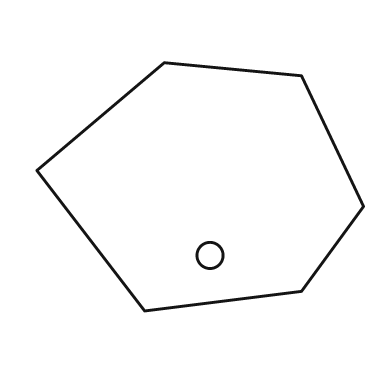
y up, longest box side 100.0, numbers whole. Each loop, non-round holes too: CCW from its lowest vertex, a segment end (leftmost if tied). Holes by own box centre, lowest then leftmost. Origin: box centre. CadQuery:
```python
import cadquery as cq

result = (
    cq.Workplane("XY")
    .moveTo(-17.0, -38.0)
    .lineTo(31.0, -32.0)
    .lineTo(50.0, -6.0)
    .lineTo(31.0, 34.0)
    .lineTo(-11.0, 38.0)
    .lineTo(-50.0, 5.0)
    .close()
    .moveTo(3.0, -21.0)
    .circle(4.0)
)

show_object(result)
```